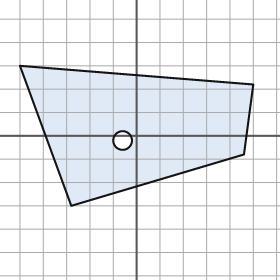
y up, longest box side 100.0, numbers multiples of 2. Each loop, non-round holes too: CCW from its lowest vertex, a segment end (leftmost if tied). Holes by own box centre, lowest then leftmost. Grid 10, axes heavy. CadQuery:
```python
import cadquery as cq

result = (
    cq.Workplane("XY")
    .moveTo(-28.0, -30.0)
    .lineTo(46.0, -8.0)
    .lineTo(50.0, 22.0)
    .lineTo(-50.0, 30.0)
    .close()
    .moveTo(-6.0, -2.0)
    .circle(4.0)
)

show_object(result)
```